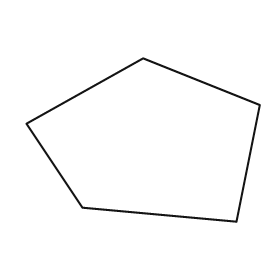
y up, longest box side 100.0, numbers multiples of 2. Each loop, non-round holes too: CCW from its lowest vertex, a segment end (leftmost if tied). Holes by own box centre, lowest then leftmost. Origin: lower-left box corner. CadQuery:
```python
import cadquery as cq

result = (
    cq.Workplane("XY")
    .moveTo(90.0, 0.0)
    .lineTo(100.0, 50.0)
    .lineTo(50.0, 70.0)
    .lineTo(0.0, 42.0)
    .lineTo(24.0, 6.0)
    .close()
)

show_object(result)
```